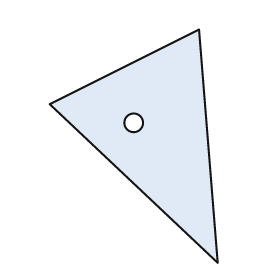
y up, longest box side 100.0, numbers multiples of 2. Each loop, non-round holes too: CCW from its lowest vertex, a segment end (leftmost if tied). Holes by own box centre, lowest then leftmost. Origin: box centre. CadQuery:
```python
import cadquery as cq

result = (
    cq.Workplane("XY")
    .moveTo(36.0, -50.0)
    .lineTo(28.0, 50.0)
    .lineTo(-36.0, 18.0)
    .close()
    .moveTo(0.0, 10.0)
    .circle(4.0)
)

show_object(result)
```